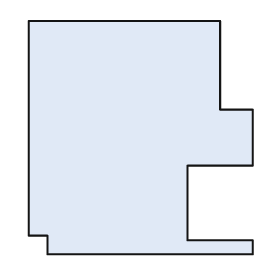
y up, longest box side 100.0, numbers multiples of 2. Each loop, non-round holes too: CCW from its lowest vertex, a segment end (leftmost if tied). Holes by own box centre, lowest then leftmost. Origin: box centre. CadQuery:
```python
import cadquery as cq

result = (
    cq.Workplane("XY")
    .moveTo(-40.0, -50.0)
    .lineTo(48.0, -50.0)
    .lineTo(48.0, -44.0)
    .lineTo(20.0, -44.0)
    .lineTo(20.0, -12.0)
    .lineTo(48.0, -12.0)
    .lineTo(48.0, 12.0)
    .lineTo(34.0, 12.0)
    .lineTo(34.0, 50.0)
    .lineTo(-48.0, 50.0)
    .lineTo(-48.0, -42.0)
    .lineTo(-40.0, -42.0)
    .close()
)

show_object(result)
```